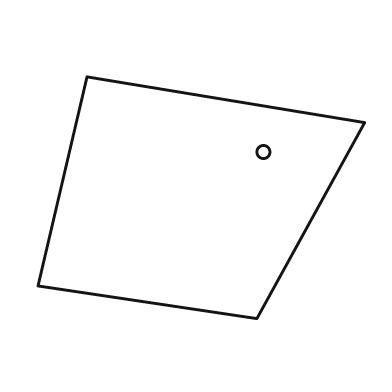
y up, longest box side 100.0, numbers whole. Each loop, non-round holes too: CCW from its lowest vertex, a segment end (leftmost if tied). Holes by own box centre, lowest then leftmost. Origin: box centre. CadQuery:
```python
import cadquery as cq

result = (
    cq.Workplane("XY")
    .moveTo(17.0, -37.0)
    .lineTo(50.0, 23.0)
    .lineTo(-35.0, 37.0)
    .lineTo(-50.0, -27.0)
    .close()
    .moveTo(19.0, 14.0)
    .circle(2.0)
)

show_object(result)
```